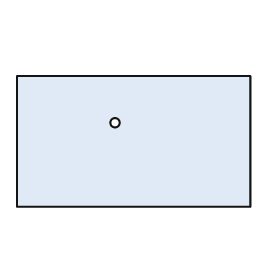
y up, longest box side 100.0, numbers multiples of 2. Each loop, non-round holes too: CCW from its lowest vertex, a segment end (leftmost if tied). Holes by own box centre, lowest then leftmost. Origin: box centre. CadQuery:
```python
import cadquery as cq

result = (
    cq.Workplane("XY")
    .moveTo(-50.0, -28.0)
    .lineTo(50.0, -28.0)
    .lineTo(50.0, 28.0)
    .lineTo(-50.0, 28.0)
    .close()
    .moveTo(-8.0, 8.0)
    .circle(2.0)
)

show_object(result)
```